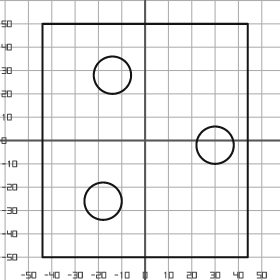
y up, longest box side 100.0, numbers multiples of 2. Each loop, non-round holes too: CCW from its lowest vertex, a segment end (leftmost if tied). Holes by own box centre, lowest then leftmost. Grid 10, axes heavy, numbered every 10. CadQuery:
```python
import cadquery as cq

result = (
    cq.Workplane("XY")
    .moveTo(-44.0, -50.0)
    .lineTo(44.0, -50.0)
    .lineTo(44.0, 50.0)
    .lineTo(-44.0, 50.0)
    .close()
    .moveTo(-18.0, -26.0)
    .circle(8.0)
    .moveTo(30.0, -2.0)
    .circle(8.0)
    .moveTo(-14.0, 28.0)
    .circle(8.0)
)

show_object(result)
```